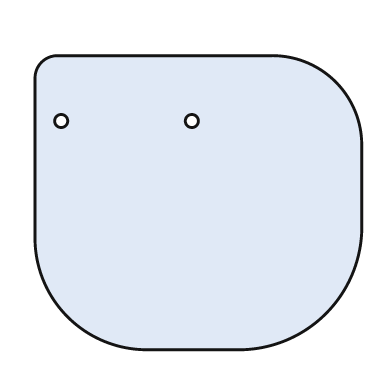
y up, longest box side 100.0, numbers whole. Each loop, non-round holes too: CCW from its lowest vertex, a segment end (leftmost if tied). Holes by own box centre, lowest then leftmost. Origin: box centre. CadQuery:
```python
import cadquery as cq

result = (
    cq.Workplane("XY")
    .moveTo(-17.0, -45.0)
    .lineTo(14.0, -45.0)
    .threePointArc((39.0, -34.0), (50.0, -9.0))
    .lineTo(50.0, 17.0)
    .threePointArc((42.0, 37.0), (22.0, 45.0))
    .lineTo(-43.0, 45.0)
    .threePointArc((-48.0, 43.0), (-50.0, 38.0))
    .lineTo(-50.0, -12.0)
    .threePointArc((-40.0, -35.0), (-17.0, -45.0))
    .close()
    .moveTo(-42.0, 25.0)
    .circle(2.0)
    .moveTo(-2.0, 25.0)
    .circle(2.0)
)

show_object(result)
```